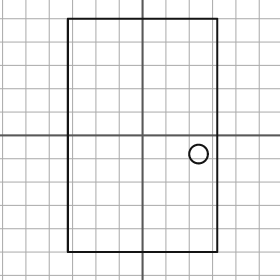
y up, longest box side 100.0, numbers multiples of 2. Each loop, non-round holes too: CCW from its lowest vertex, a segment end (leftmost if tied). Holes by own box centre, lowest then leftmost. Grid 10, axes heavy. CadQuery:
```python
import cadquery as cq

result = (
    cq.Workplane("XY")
    .moveTo(-32.0, -50.0)
    .lineTo(32.0, -50.0)
    .lineTo(32.0, 50.0)
    .lineTo(-32.0, 50.0)
    .close()
    .moveTo(24.0, -8.0)
    .circle(4.0)
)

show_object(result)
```